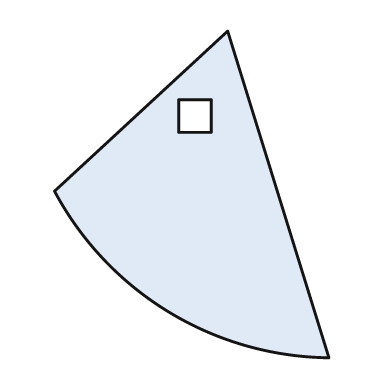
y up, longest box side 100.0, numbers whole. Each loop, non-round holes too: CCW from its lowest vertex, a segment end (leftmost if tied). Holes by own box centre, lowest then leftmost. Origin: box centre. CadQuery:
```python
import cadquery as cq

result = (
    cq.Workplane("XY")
    .moveTo(42.0, -50.0)
    .lineTo(11.0, 50.0)
    .lineTo(-42.0, 1.0)
    .threePointArc((-7.0, -36.0), (42.0, -50.0))
    .close()
    .moveTo(-4.0, 19.0)
    .lineTo(6.0, 19.0)
    .lineTo(6.0, 29.0)
    .lineTo(-4.0, 29.0)
    .close()
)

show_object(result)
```